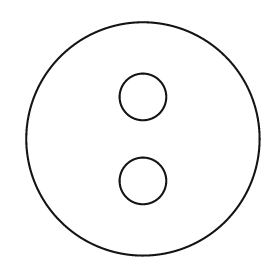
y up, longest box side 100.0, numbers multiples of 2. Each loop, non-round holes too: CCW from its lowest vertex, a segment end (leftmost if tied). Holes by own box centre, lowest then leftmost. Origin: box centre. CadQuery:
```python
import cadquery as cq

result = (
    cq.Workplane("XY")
    .moveTo(0.0, 0.0)
    .circle(50.0)
    .moveTo(0.0, -18.0)
    .circle(10.0)
    .moveTo(0.0, 18.0)
    .circle(10.0)
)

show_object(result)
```